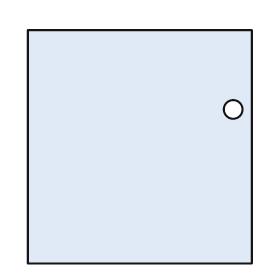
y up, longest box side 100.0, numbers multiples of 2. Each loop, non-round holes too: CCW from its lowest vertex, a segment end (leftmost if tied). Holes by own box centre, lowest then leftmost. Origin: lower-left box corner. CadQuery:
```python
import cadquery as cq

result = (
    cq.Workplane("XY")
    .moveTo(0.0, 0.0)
    .lineTo(96.0, 0.0)
    .lineTo(96.0, 100.0)
    .lineTo(0.0, 100.0)
    .close()
    .moveTo(88.0, 66.0)
    .circle(4.0)
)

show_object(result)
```